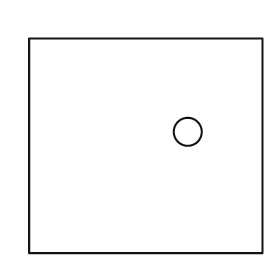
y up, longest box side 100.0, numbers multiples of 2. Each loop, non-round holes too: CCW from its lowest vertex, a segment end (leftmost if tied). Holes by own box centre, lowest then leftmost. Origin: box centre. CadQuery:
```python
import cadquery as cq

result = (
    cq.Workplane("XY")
    .moveTo(-50.0, -46.0)
    .lineTo(50.0, -46.0)
    .lineTo(50.0, 46.0)
    .lineTo(-50.0, 46.0)
    .close()
    .moveTo(18.0, 6.0)
    .circle(6.0)
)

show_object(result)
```